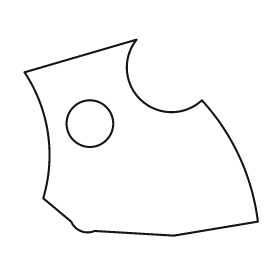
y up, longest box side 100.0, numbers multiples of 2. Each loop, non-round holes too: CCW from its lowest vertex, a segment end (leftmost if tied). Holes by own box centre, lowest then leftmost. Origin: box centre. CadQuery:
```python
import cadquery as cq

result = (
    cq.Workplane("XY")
    .moveTo(14.0, -42.0)
    .lineTo(50.0, -36.0)
    .threePointArc((42.0, -8.0), (26.0, 16.0))
    .threePointArc((0.0, 16.0), (-2.0, 42.0))
    .lineTo(-50.0, 28.0)
    .threePointArc((-40.0, 2.0), (-42.0, -26.0))
    .lineTo(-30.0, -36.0)
    .threePointArc((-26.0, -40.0), (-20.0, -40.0))
    .close()
    .moveTo(-22.0, 6.0)
    .circle(10.0)
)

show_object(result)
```